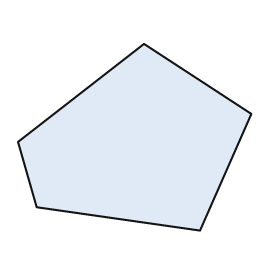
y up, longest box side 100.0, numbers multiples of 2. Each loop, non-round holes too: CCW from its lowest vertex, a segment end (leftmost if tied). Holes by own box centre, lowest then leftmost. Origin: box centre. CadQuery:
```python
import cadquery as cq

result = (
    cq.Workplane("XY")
    .moveTo(28.0, -40.0)
    .lineTo(50.0, 10.0)
    .lineTo(4.0, 40.0)
    .lineTo(-50.0, -2.0)
    .lineTo(-42.0, -30.0)
    .close()
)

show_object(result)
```